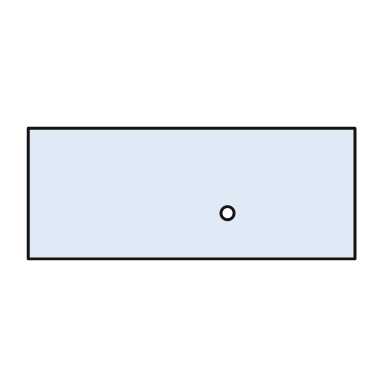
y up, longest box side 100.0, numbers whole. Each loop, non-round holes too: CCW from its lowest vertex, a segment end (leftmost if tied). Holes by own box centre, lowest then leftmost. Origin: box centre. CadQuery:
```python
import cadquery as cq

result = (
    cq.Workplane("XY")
    .moveTo(-50.0, -20.0)
    .lineTo(50.0, -20.0)
    .lineTo(50.0, 20.0)
    .lineTo(-50.0, 20.0)
    .close()
    .moveTo(11.0, -6.0)
    .circle(2.0)
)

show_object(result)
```